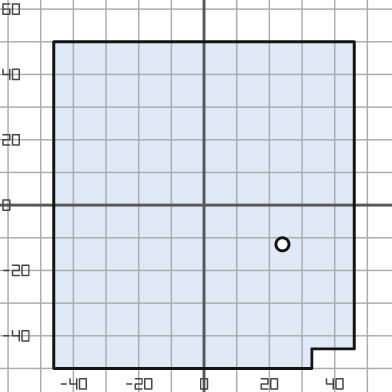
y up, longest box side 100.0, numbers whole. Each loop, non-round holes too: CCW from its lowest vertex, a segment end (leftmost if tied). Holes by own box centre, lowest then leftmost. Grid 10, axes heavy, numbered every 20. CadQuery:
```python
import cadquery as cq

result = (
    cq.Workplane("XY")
    .moveTo(-46.0, -50.0)
    .lineTo(33.0, -50.0)
    .lineTo(33.0, -44.0)
    .lineTo(46.0, -44.0)
    .lineTo(46.0, 50.0)
    .lineTo(-46.0, 50.0)
    .close()
    .moveTo(24.0, -12.0)
    .circle(2.0)
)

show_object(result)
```